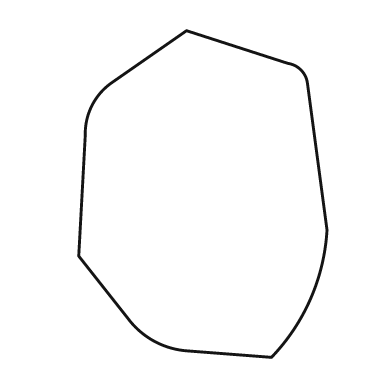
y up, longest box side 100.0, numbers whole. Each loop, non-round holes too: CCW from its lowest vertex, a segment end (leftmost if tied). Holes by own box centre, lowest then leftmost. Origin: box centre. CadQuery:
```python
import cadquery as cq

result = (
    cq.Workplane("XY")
    .moveTo(21.0, -50.0)
    .threePointArc((33.0, -32.0), (38.0, -11.0))
    .lineTo(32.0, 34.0)
    .threePointArc((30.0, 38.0), (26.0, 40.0))
    .lineTo(-5.0, 50.0)
    .lineTo(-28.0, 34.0)
    .threePointArc((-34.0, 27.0), (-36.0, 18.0))
    .lineTo(-38.0, -19.0)
    .lineTo(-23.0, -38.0)
    .threePointArc((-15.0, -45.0), (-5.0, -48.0))
    .close()
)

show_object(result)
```